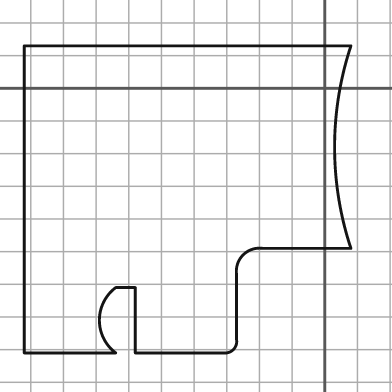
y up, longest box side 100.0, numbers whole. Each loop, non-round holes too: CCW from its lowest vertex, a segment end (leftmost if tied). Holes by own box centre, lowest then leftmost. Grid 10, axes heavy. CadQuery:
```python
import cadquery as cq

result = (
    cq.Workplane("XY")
    .moveTo(-92.0, -81.0)
    .lineTo(-64.0, -81.0)
    .threePointArc((-69.0, -71.0), (-64.0, -61.0))
    .lineTo(-58.0, -61.0)
    .lineTo(-58.0, -81.0)
    .lineTo(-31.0, -81.0)
    .threePointArc((-28.0, -80.0), (-27.0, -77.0))
    .lineTo(-27.0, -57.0)
    .threePointArc((-25.0, -51.0), (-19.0, -49.0))
    .lineTo(8.0, -49.0)
    .threePointArc((3.0, -18.0), (8.0, 13.0))
    .lineTo(-92.0, 13.0)
    .close()
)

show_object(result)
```